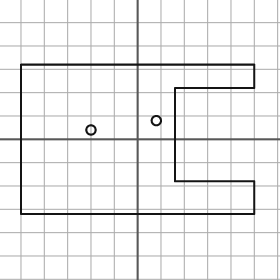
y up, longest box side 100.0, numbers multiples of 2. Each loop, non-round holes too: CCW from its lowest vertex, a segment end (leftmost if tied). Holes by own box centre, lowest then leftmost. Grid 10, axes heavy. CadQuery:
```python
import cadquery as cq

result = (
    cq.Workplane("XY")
    .moveTo(-50.0, -32.0)
    .lineTo(50.0, -32.0)
    .lineTo(50.0, -18.0)
    .lineTo(16.0, -18.0)
    .lineTo(16.0, 22.0)
    .lineTo(50.0, 22.0)
    .lineTo(50.0, 32.0)
    .lineTo(-50.0, 32.0)
    .close()
    .moveTo(-20.0, 4.0)
    .circle(2.0)
    .moveTo(8.0, 8.0)
    .circle(2.0)
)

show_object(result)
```